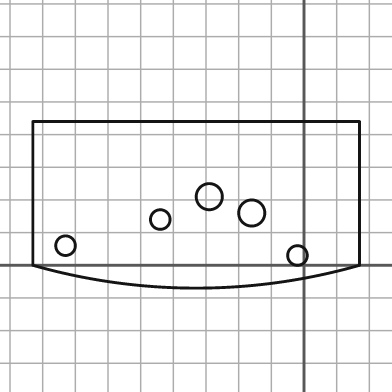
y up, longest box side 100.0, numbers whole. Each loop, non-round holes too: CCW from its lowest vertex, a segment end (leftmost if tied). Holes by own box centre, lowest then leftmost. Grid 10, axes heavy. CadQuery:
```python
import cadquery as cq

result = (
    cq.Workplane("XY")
    .moveTo(-83.0, 0.0)
    .threePointArc((-33.0, -7.0), (17.0, 0.0))
    .lineTo(17.0, 44.0)
    .lineTo(-83.0, 44.0)
    .close()
    .moveTo(-2.0, 3.0)
    .circle(3.0)
    .moveTo(-73.0, 6.0)
    .circle(3.0)
    .moveTo(-44.0, 14.0)
    .circle(3.0)
    .moveTo(-16.0, 16.0)
    .circle(4.0)
    .moveTo(-29.0, 21.0)
    .circle(4.0)
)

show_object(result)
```